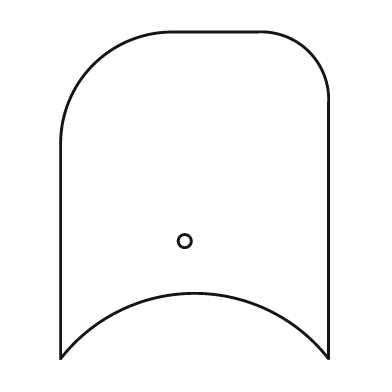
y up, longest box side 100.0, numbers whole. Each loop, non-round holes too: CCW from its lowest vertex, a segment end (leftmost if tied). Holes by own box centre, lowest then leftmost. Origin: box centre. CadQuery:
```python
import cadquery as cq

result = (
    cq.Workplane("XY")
    .moveTo(-41.0, -50.0)
    .threePointArc((0.0, -30.0), (41.0, -50.0))
    .lineTo(41.0, 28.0)
    .threePointArc((35.0, 44.0), (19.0, 50.0))
    .lineTo(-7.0, 50.0)
    .threePointArc((-31.0, 40.0), (-41.0, 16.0))
    .close()
    .moveTo(-3.0, -14.0)
    .circle(2.0)
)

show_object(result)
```